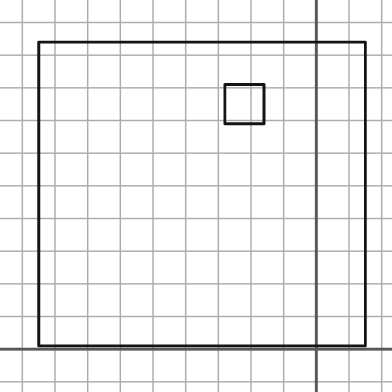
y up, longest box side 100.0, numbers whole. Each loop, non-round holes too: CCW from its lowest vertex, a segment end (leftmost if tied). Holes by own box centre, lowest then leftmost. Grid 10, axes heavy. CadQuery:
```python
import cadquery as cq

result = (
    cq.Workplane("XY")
    .moveTo(-85.0, 1.0)
    .lineTo(15.0, 1.0)
    .lineTo(15.0, 94.0)
    .lineTo(-85.0, 94.0)
    .close()
    .moveTo(-28.0, 69.0)
    .lineTo(-16.0, 69.0)
    .lineTo(-16.0, 81.0)
    .lineTo(-28.0, 81.0)
    .close()
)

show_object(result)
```